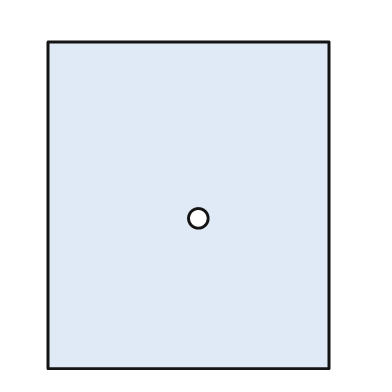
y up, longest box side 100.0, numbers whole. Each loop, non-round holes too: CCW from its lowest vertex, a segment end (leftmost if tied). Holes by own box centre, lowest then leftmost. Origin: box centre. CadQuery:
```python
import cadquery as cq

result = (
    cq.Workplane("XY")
    .moveTo(-43.0, -50.0)
    .lineTo(43.0, -50.0)
    .lineTo(43.0, 50.0)
    .lineTo(-43.0, 50.0)
    .close()
    .moveTo(3.0, -4.0)
    .circle(3.0)
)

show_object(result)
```